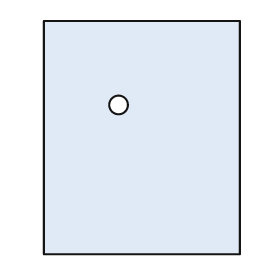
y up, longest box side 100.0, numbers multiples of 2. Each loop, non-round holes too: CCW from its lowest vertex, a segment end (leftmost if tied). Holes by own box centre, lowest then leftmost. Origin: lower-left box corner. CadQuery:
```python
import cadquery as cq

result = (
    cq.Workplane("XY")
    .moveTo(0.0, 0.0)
    .lineTo(84.0, 0.0)
    .lineTo(84.0, 100.0)
    .lineTo(0.0, 100.0)
    .close()
    .moveTo(32.0, 64.0)
    .circle(4.0)
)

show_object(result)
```